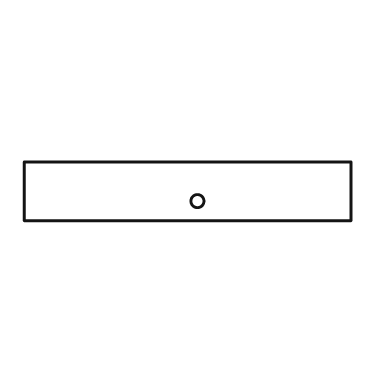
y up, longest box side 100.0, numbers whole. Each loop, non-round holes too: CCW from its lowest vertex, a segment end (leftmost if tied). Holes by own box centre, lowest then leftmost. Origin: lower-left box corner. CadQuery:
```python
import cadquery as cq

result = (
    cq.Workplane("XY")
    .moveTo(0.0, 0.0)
    .lineTo(100.0, 0.0)
    .lineTo(100.0, 18.0)
    .lineTo(0.0, 18.0)
    .close()
    .moveTo(53.0, 6.0)
    .circle(2.0)
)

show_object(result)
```